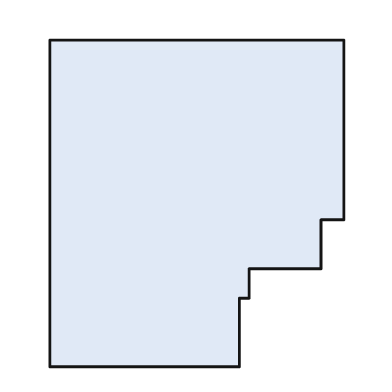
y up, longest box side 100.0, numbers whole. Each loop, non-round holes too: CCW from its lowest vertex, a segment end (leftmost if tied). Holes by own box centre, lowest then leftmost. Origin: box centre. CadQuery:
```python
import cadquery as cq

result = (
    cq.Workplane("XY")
    .moveTo(-45.0, -50.0)
    .lineTo(13.0, -50.0)
    .lineTo(13.0, -29.0)
    .lineTo(16.0, -29.0)
    .lineTo(16.0, -20.0)
    .lineTo(38.0, -20.0)
    .lineTo(38.0, -5.0)
    .lineTo(45.0, -5.0)
    .lineTo(45.0, 50.0)
    .lineTo(-45.0, 50.0)
    .close()
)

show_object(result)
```